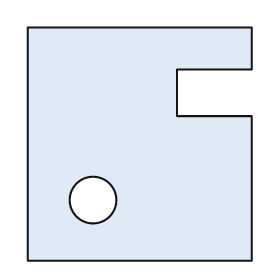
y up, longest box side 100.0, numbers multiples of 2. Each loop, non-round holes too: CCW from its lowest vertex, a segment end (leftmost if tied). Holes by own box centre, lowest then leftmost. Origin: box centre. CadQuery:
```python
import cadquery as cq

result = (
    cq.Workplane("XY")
    .moveTo(-48.0, -50.0)
    .lineTo(48.0, -50.0)
    .lineTo(48.0, 12.0)
    .lineTo(16.0, 12.0)
    .lineTo(16.0, 32.0)
    .lineTo(48.0, 32.0)
    .lineTo(48.0, 50.0)
    .lineTo(-48.0, 50.0)
    .close()
    .moveTo(-20.0, -24.0)
    .circle(10.0)
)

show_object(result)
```